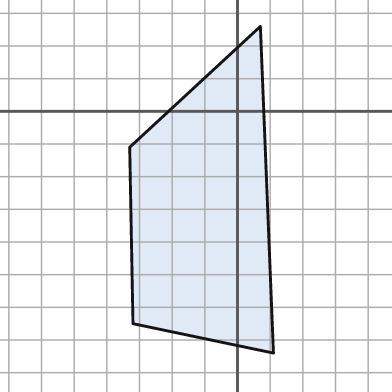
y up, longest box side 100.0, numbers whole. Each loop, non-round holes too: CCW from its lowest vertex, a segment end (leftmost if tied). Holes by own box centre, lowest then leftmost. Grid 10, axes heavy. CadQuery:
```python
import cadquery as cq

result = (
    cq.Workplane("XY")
    .moveTo(11.0, -74.0)
    .lineTo(7.0, 26.0)
    .lineTo(-33.0, -11.0)
    .lineTo(-32.0, -65.0)
    .close()
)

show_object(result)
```